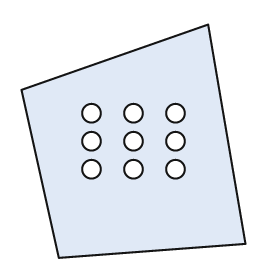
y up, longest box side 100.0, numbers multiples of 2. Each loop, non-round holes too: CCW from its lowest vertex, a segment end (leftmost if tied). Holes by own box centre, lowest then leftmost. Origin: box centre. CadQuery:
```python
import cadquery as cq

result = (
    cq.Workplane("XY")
    .moveTo(-32.0, -50.0)
    .lineTo(48.0, -44.0)
    .lineTo(32.0, 50.0)
    .lineTo(-48.0, 22.0)
    .close()
    .moveTo(-18.0, -12.0)
    .circle(4.0)
    .moveTo(0.0, -12.0)
    .circle(4.0)
    .moveTo(18.0, -12.0)
    .circle(4.0)
    .moveTo(-18.0, 0.0)
    .circle(4.0)
    .moveTo(0.0, 0.0)
    .circle(4.0)
    .moveTo(18.0, 0.0)
    .circle(4.0)
    .moveTo(-18.0, 12.0)
    .circle(4.0)
    .moveTo(0.0, 12.0)
    .circle(4.0)
    .moveTo(18.0, 12.0)
    .circle(4.0)
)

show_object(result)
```